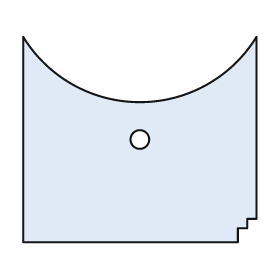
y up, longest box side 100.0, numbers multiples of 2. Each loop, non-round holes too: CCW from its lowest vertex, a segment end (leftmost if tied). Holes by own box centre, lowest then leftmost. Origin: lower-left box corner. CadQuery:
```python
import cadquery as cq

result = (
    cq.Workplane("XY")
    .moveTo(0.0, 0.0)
    .lineTo(92.0, 0.0)
    .lineTo(92.0, 6.0)
    .lineTo(96.0, 6.0)
    .lineTo(96.0, 10.0)
    .lineTo(100.0, 10.0)
    .lineTo(100.0, 88.0)
    .threePointArc((50.0, 60.0), (0.0, 88.0))
    .close()
    .moveTo(50.0, 44.0)
    .circle(4.0)
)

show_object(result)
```